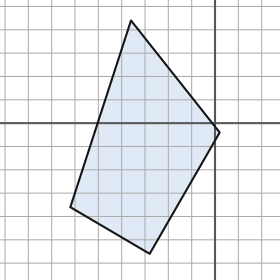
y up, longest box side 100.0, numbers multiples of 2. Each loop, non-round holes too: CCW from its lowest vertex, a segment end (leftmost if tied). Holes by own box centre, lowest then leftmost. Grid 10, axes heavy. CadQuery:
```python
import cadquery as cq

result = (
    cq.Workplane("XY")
    .moveTo(-28.0, -56.0)
    .lineTo(2.0, -4.0)
    .lineTo(-36.0, 44.0)
    .lineTo(-62.0, -36.0)
    .close()
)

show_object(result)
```